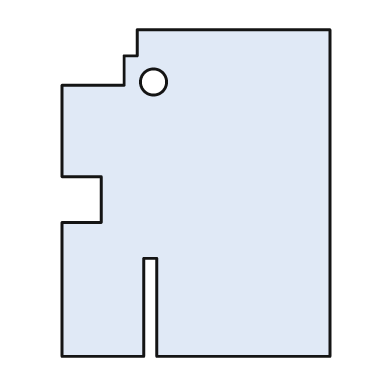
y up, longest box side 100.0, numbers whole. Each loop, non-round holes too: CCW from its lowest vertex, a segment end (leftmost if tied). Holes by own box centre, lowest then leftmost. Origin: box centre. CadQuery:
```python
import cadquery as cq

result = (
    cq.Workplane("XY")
    .moveTo(-41.0, -50.0)
    .lineTo(-16.0, -50.0)
    .lineTo(-16.0, -20.0)
    .lineTo(-12.0, -20.0)
    .lineTo(-12.0, -50.0)
    .lineTo(41.0, -50.0)
    .lineTo(41.0, 50.0)
    .lineTo(-18.0, 50.0)
    .lineTo(-18.0, 42.0)
    .lineTo(-22.0, 42.0)
    .lineTo(-22.0, 33.0)
    .lineTo(-41.0, 33.0)
    .lineTo(-41.0, 5.0)
    .lineTo(-29.0, 5.0)
    .lineTo(-29.0, -9.0)
    .lineTo(-41.0, -9.0)
    .close()
    .moveTo(-13.0, 34.0)
    .circle(4.0)
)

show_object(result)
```